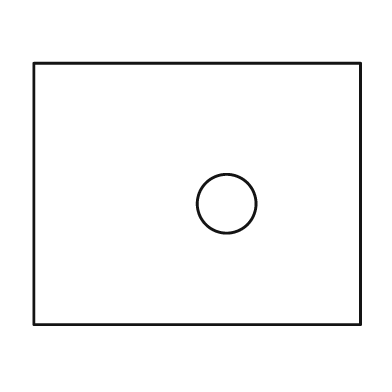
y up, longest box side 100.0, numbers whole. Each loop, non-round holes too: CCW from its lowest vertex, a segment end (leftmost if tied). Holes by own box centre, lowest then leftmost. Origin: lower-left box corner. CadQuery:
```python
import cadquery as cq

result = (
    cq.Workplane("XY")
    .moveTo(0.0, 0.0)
    .lineTo(100.0, 0.0)
    .lineTo(100.0, 80.0)
    .lineTo(0.0, 80.0)
    .close()
    .moveTo(59.0, 37.0)
    .circle(9.0)
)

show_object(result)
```